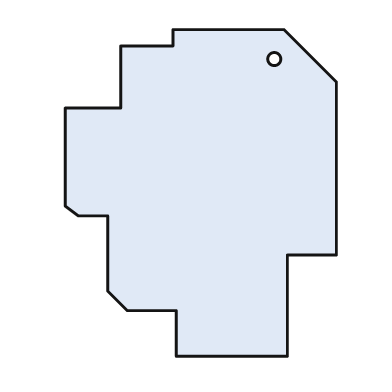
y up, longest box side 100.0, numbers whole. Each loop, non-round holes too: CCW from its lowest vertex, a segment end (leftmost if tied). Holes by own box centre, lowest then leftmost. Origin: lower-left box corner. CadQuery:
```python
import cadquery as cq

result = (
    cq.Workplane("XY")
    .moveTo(34.0, 0.0)
    .lineTo(68.0, 0.0)
    .lineTo(68.0, 31.0)
    .lineTo(83.0, 31.0)
    .lineTo(83.0, 84.0)
    .lineTo(67.0, 100.0)
    .lineTo(33.0, 100.0)
    .lineTo(33.0, 95.0)
    .lineTo(17.0, 95.0)
    .lineTo(17.0, 76.0)
    .lineTo(0.0, 76.0)
    .lineTo(0.0, 46.0)
    .lineTo(4.0, 43.0)
    .lineTo(13.0, 43.0)
    .lineTo(13.0, 20.0)
    .lineTo(19.0, 14.0)
    .lineTo(34.0, 14.0)
    .close()
    .moveTo(64.0, 91.0)
    .circle(2.0)
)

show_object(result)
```